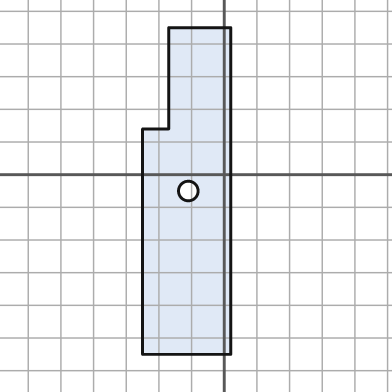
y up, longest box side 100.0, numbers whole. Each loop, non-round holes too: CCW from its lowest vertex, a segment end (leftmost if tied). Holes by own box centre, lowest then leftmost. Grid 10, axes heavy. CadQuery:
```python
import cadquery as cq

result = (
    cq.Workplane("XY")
    .moveTo(-25.0, -55.0)
    .lineTo(2.0, -55.0)
    .lineTo(2.0, 45.0)
    .lineTo(-17.0, 45.0)
    .lineTo(-17.0, 14.0)
    .lineTo(-25.0, 14.0)
    .close()
    .moveTo(-11.0, -5.0)
    .circle(3.0)
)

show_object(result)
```